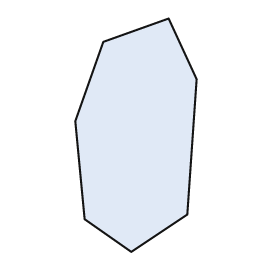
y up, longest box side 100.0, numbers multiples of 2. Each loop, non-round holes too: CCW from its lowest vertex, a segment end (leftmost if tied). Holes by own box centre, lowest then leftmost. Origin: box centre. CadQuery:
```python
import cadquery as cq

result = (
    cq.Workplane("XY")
    .moveTo(-2.0, -50.0)
    .lineTo(22.0, -34.0)
    .lineTo(26.0, 24.0)
    .lineTo(14.0, 50.0)
    .lineTo(-14.0, 40.0)
    .lineTo(-26.0, 6.0)
    .lineTo(-22.0, -36.0)
    .close()
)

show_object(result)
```